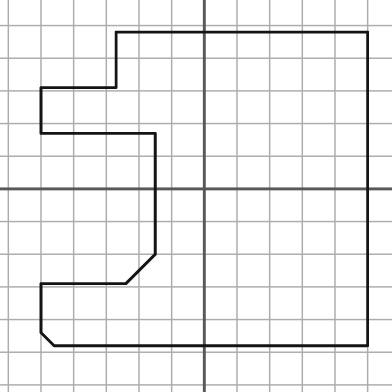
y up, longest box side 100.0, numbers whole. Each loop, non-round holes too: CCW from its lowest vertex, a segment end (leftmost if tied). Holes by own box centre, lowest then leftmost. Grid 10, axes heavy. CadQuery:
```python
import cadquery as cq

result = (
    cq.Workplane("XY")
    .moveTo(-46.0, -48.0)
    .lineTo(50.0, -48.0)
    .lineTo(50.0, 48.0)
    .lineTo(-27.0, 48.0)
    .lineTo(-27.0, 31.0)
    .lineTo(-50.0, 31.0)
    .lineTo(-50.0, 17.0)
    .lineTo(-15.0, 17.0)
    .lineTo(-15.0, -20.0)
    .lineTo(-24.0, -29.0)
    .lineTo(-50.0, -29.0)
    .lineTo(-50.0, -44.0)
    .close()
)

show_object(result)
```